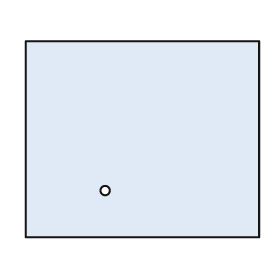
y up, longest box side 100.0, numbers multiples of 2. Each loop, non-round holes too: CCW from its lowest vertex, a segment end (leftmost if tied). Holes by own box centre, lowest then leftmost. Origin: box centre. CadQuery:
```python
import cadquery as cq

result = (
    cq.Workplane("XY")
    .moveTo(-50.0, -42.0)
    .lineTo(50.0, -42.0)
    .lineTo(50.0, 42.0)
    .lineTo(-50.0, 42.0)
    .close()
    .moveTo(-16.0, -22.0)
    .circle(2.0)
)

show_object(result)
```